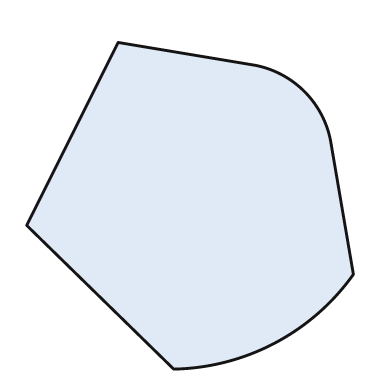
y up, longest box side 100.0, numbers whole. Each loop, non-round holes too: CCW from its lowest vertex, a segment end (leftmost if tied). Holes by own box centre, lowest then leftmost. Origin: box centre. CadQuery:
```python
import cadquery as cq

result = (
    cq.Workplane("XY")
    .moveTo(-5.0, -50.0)
    .threePointArc((26.0, -42.0), (50.0, -21.0))
    .lineTo(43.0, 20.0)
    .threePointArc((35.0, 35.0), (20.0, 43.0))
    .lineTo(-22.0, 50.0)
    .lineTo(-50.0, -6.0)
    .close()
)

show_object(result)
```